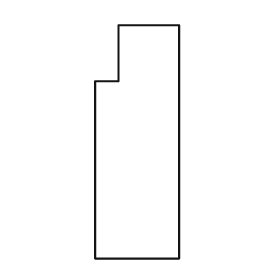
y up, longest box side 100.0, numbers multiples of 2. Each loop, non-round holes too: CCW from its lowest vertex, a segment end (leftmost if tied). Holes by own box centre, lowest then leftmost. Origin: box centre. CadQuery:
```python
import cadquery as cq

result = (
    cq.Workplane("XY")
    .moveTo(-18.0, -50.0)
    .lineTo(18.0, -50.0)
    .lineTo(18.0, 50.0)
    .lineTo(-8.0, 50.0)
    .lineTo(-8.0, 26.0)
    .lineTo(-18.0, 26.0)
    .close()
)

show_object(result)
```